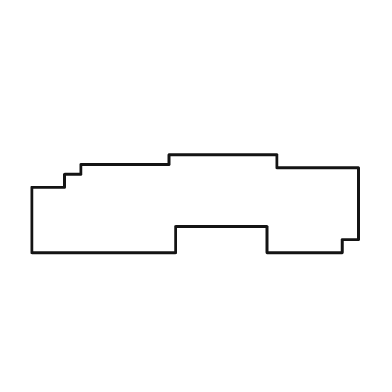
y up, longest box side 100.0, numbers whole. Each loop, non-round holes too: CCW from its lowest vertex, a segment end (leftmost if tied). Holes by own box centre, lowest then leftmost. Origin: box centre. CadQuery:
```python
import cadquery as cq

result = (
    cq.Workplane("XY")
    .moveTo(-50.0, -15.0)
    .lineTo(-6.0, -15.0)
    .lineTo(-6.0, -7.0)
    .lineTo(22.0, -7.0)
    .lineTo(22.0, -15.0)
    .lineTo(45.0, -15.0)
    .lineTo(45.0, -11.0)
    .lineTo(50.0, -11.0)
    .lineTo(50.0, 11.0)
    .lineTo(25.0, 11.0)
    .lineTo(25.0, 15.0)
    .lineTo(-8.0, 15.0)
    .lineTo(-8.0, 12.0)
    .lineTo(-35.0, 12.0)
    .lineTo(-35.0, 9.0)
    .lineTo(-40.0, 9.0)
    .lineTo(-40.0, 5.0)
    .lineTo(-50.0, 5.0)
    .close()
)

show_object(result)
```